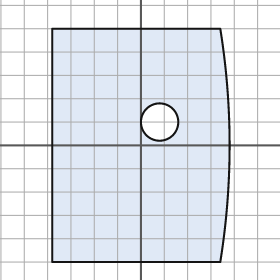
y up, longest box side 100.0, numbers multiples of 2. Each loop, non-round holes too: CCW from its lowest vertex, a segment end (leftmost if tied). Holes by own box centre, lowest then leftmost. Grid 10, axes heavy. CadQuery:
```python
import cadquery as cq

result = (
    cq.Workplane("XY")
    .moveTo(-38.0, -50.0)
    .lineTo(34.0, -50.0)
    .threePointArc((38.0, 0.0), (34.0, 50.0))
    .lineTo(-38.0, 50.0)
    .close()
    .moveTo(8.0, 10.0)
    .circle(8.0)
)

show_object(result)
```